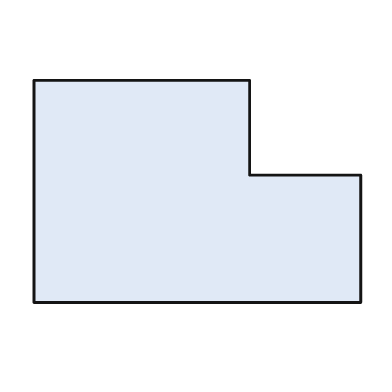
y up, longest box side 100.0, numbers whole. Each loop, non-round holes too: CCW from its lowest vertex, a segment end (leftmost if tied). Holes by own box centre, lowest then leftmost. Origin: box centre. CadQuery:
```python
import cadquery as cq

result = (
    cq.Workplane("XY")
    .moveTo(-50.0, -34.0)
    .lineTo(50.0, -34.0)
    .lineTo(50.0, 5.0)
    .lineTo(16.0, 5.0)
    .lineTo(16.0, 34.0)
    .lineTo(-50.0, 34.0)
    .close()
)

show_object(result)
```